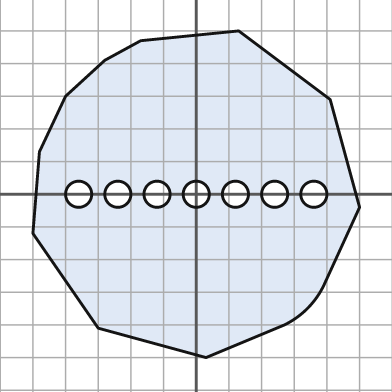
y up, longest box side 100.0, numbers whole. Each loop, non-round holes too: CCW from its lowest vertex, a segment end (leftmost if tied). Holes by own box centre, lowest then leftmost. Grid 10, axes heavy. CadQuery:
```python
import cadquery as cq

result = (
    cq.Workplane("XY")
    .moveTo(3.0, -50.0)
    .lineTo(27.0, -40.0)
    .threePointArc((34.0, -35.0), (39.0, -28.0))
    .lineTo(50.0, -4.0)
    .lineTo(41.0, 29.0)
    .lineTo(13.0, 50.0)
    .lineTo(-17.0, 47.0)
    .lineTo(-28.0, 41.0)
    .lineTo(-40.0, 30.0)
    .lineTo(-48.0, 13.0)
    .lineTo(-50.0, -12.0)
    .lineTo(-30.0, -41.0)
    .close()
    .moveTo(-36.0, 0.0)
    .circle(4.0)
    .moveTo(-24.0, 0.0)
    .circle(4.0)
    .moveTo(-12.0, 0.0)
    .circle(4.0)
    .moveTo(0.0, 0.0)
    .circle(4.0)
    .moveTo(12.0, 0.0)
    .circle(4.0)
    .moveTo(24.0, 0.0)
    .circle(4.0)
    .moveTo(36.0, 0.0)
    .circle(4.0)
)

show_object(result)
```